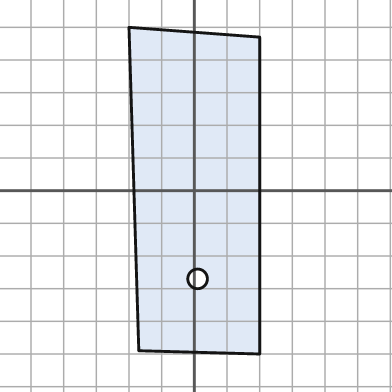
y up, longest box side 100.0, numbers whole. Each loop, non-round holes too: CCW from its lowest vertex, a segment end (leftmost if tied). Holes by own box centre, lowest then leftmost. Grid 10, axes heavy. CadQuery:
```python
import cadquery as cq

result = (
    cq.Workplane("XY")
    .moveTo(20.0, -50.0)
    .lineTo(20.0, 47.0)
    .lineTo(-20.0, 50.0)
    .lineTo(-17.0, -49.0)
    .close()
    .moveTo(1.0, -27.0)
    .circle(3.0)
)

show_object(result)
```